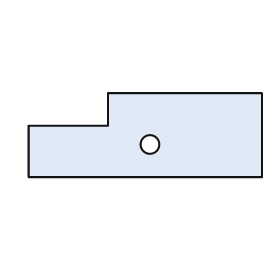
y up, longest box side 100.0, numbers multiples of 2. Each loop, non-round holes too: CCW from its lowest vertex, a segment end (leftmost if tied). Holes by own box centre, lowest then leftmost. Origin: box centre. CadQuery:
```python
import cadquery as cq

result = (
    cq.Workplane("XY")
    .moveTo(-50.0, -18.0)
    .lineTo(50.0, -18.0)
    .lineTo(50.0, 18.0)
    .lineTo(-16.0, 18.0)
    .lineTo(-16.0, 4.0)
    .lineTo(-50.0, 4.0)
    .close()
    .moveTo(2.0, -4.0)
    .circle(4.0)
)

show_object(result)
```